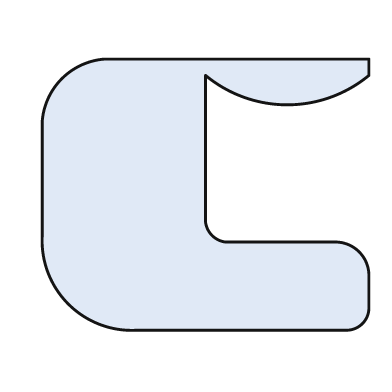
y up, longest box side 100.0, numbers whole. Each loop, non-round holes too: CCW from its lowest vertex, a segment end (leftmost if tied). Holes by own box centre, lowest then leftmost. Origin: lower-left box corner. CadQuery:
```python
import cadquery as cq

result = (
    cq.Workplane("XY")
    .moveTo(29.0, 0.0)
    .lineTo(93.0, 0.0)
    .threePointArc((98.0, 2.0), (100.0, 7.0))
    .lineTo(100.0, 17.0)
    .threePointArc((97.0, 24.0), (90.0, 27.0))
    .lineTo(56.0, 27.0)
    .threePointArc((52.0, 29.0), (50.0, 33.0))
    .lineTo(50.0, 78.0)
    .threePointArc((75.0, 69.0), (100.0, 78.0))
    .lineTo(100.0, 83.0)
    .lineTo(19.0, 83.0)
    .threePointArc((6.0, 77.0), (0.0, 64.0))
    .lineTo(0.0, 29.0)
    .threePointArc((8.0, 8.0), (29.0, 0.0))
    .close()
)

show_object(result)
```